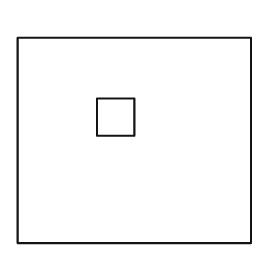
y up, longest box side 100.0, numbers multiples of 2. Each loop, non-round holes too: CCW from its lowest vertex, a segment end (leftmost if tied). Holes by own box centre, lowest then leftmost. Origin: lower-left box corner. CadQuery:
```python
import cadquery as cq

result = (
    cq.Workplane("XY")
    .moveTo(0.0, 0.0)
    .lineTo(100.0, 0.0)
    .lineTo(100.0, 88.0)
    .lineTo(0.0, 88.0)
    .close()
    .moveTo(34.0, 46.0)
    .lineTo(50.0, 46.0)
    .lineTo(50.0, 62.0)
    .lineTo(34.0, 62.0)
    .close()
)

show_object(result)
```